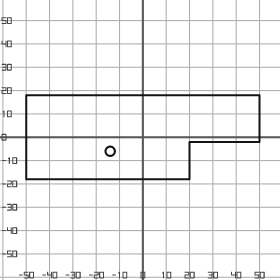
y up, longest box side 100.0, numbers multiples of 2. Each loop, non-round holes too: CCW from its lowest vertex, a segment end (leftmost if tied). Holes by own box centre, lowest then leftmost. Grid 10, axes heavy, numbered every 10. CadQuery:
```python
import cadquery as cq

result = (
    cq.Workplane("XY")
    .moveTo(-50.0, -18.0)
    .lineTo(20.0, -18.0)
    .lineTo(20.0, -2.0)
    .lineTo(50.0, -2.0)
    .lineTo(50.0, 18.0)
    .lineTo(-50.0, 18.0)
    .close()
    .moveTo(-14.0, -6.0)
    .circle(2.0)
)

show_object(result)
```